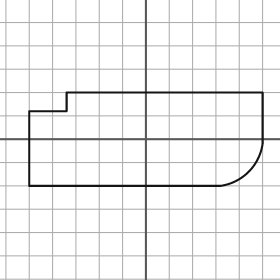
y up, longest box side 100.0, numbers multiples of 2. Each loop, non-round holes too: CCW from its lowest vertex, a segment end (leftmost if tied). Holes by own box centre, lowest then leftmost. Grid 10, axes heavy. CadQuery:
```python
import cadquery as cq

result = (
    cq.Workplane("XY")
    .moveTo(-50.0, -20.0)
    .lineTo(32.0, -20.0)
    .threePointArc((44.0, -14.0), (50.0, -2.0))
    .lineTo(50.0, 20.0)
    .lineTo(-34.0, 20.0)
    .lineTo(-34.0, 12.0)
    .lineTo(-50.0, 12.0)
    .close()
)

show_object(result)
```